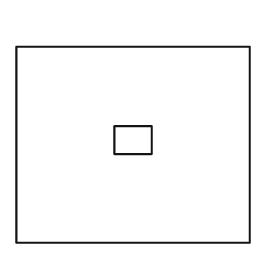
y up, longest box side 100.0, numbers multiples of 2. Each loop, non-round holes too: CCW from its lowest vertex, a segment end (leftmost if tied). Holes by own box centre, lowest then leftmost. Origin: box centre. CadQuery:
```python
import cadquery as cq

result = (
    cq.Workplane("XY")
    .moveTo(-50.0, -42.0)
    .lineTo(50.0, -42.0)
    .lineTo(50.0, 42.0)
    .lineTo(-50.0, 42.0)
    .close()
    .moveTo(-8.0, -4.0)
    .lineTo(8.0, -4.0)
    .lineTo(8.0, 8.0)
    .lineTo(-8.0, 8.0)
    .close()
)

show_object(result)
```